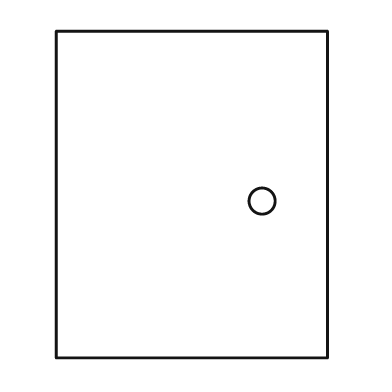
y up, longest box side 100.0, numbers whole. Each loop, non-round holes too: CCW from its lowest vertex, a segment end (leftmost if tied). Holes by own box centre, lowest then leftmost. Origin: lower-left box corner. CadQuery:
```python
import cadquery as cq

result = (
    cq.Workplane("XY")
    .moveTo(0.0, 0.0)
    .lineTo(83.0, 0.0)
    .lineTo(83.0, 100.0)
    .lineTo(0.0, 100.0)
    .close()
    .moveTo(63.0, 48.0)
    .circle(4.0)
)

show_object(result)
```